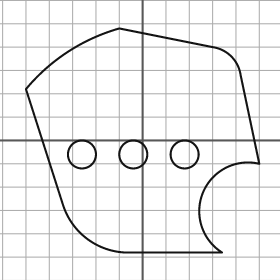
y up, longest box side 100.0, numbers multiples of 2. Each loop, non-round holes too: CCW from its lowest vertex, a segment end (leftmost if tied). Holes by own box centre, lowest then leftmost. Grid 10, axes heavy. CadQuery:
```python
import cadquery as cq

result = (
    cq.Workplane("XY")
    .moveTo(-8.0, -48.0)
    .lineTo(34.0, -48.0)
    .threePointArc((26.0, -22.0), (50.0, -10.0))
    .lineTo(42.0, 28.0)
    .threePointArc((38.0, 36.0), (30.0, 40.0))
    .lineTo(-10.0, 48.0)
    .threePointArc((-32.0, 38.0), (-50.0, 22.0))
    .lineTo(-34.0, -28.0)
    .threePointArc((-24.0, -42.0), (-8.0, -48.0))
    .close()
    .moveTo(-26.0, -6.0)
    .circle(6.0)
    .moveTo(-4.0, -6.0)
    .circle(6.0)
    .moveTo(18.0, -6.0)
    .circle(6.0)
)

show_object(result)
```